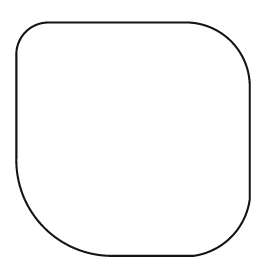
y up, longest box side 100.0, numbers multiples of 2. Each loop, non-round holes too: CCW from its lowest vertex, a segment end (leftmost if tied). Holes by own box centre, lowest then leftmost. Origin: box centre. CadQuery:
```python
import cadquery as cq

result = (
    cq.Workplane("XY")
    .moveTo(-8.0, -50.0)
    .lineTo(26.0, -50.0)
    .threePointArc((42.0, -42.0), (50.0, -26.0))
    .lineTo(50.0, 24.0)
    .threePointArc((42.0, 42.0), (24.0, 50.0))
    .lineTo(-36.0, 50.0)
    .threePointArc((-46.0, 46.0), (-50.0, 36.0))
    .lineTo(-50.0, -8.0)
    .threePointArc((-38.0, -38.0), (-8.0, -50.0))
    .close()
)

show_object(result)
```